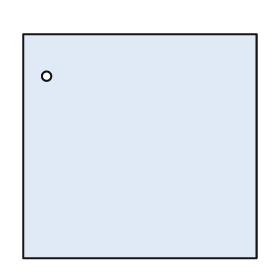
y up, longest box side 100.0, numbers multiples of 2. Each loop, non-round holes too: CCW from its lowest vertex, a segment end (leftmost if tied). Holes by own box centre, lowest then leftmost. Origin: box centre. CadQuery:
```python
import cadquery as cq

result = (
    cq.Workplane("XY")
    .moveTo(-50.0, -48.0)
    .lineTo(50.0, -48.0)
    .lineTo(50.0, 48.0)
    .lineTo(-50.0, 48.0)
    .close()
    .moveTo(-40.0, 30.0)
    .circle(2.0)
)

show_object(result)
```